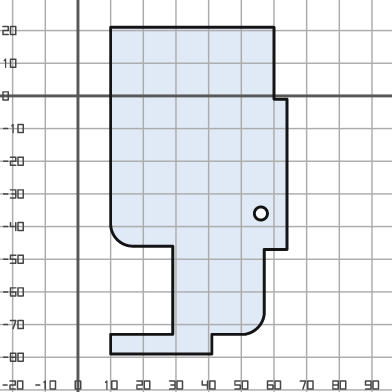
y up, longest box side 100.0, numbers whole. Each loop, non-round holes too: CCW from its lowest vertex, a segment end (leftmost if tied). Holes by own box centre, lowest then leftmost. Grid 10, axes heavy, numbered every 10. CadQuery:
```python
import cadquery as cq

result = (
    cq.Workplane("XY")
    .moveTo(10.0, -79.0)
    .lineTo(41.0, -79.0)
    .lineTo(41.0, -73.0)
    .lineTo(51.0, -73.0)
    .threePointArc((55.0, -71.0), (57.0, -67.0))
    .lineTo(57.0, -47.0)
    .lineTo(64.0, -47.0)
    .lineTo(64.0, -1.0)
    .lineTo(60.0, -1.0)
    .lineTo(60.0, 21.0)
    .lineTo(10.0, 21.0)
    .lineTo(10.0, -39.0)
    .threePointArc((12.0, -44.0), (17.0, -46.0))
    .lineTo(29.0, -46.0)
    .lineTo(29.0, -73.0)
    .lineTo(10.0, -73.0)
    .close()
    .moveTo(56.0, -36.0)
    .circle(2.0)
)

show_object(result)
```